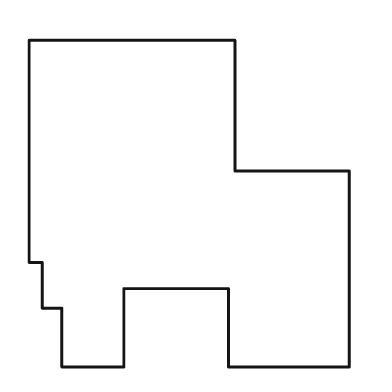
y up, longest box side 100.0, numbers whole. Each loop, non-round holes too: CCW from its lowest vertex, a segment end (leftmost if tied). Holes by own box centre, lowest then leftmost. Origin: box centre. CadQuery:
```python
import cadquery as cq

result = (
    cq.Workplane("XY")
    .moveTo(-39.0, -50.0)
    .lineTo(-20.0, -50.0)
    .lineTo(-20.0, -26.0)
    .lineTo(12.0, -26.0)
    .lineTo(12.0, -50.0)
    .lineTo(49.0, -50.0)
    .lineTo(49.0, 10.0)
    .lineTo(14.0, 10.0)
    .lineTo(14.0, 50.0)
    .lineTo(-49.0, 50.0)
    .lineTo(-49.0, -18.0)
    .lineTo(-45.0, -18.0)
    .lineTo(-45.0, -32.0)
    .lineTo(-39.0, -32.0)
    .close()
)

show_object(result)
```